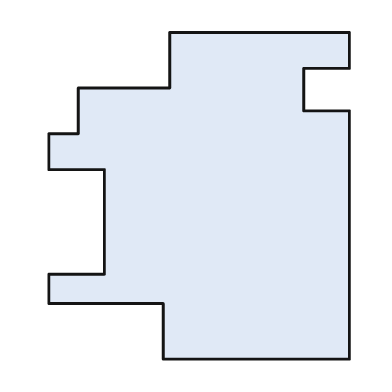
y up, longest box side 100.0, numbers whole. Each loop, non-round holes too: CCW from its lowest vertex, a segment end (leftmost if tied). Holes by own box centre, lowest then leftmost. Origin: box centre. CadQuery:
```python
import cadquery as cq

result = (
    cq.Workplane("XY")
    .moveTo(-11.0, -50.0)
    .lineTo(46.0, -50.0)
    .lineTo(46.0, 26.0)
    .lineTo(32.0, 26.0)
    .lineTo(32.0, 39.0)
    .lineTo(46.0, 39.0)
    .lineTo(46.0, 50.0)
    .lineTo(-9.0, 50.0)
    .lineTo(-9.0, 33.0)
    .lineTo(-37.0, 33.0)
    .lineTo(-37.0, 19.0)
    .lineTo(-46.0, 19.0)
    .lineTo(-46.0, 8.0)
    .lineTo(-29.0, 8.0)
    .lineTo(-29.0, -24.0)
    .lineTo(-46.0, -24.0)
    .lineTo(-46.0, -33.0)
    .lineTo(-11.0, -33.0)
    .close()
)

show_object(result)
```